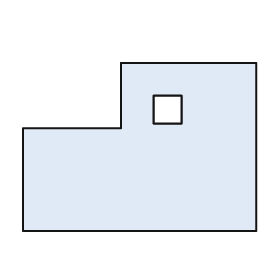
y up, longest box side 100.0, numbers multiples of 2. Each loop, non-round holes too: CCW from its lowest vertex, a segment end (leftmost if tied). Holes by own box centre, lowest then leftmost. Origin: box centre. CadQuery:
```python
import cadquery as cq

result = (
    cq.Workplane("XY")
    .moveTo(-50.0, -36.0)
    .lineTo(50.0, -36.0)
    .lineTo(50.0, 36.0)
    .lineTo(-8.0, 36.0)
    .lineTo(-8.0, 8.0)
    .lineTo(-50.0, 8.0)
    .close()
    .moveTo(6.0, 10.0)
    .lineTo(18.0, 10.0)
    .lineTo(18.0, 22.0)
    .lineTo(6.0, 22.0)
    .close()
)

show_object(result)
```